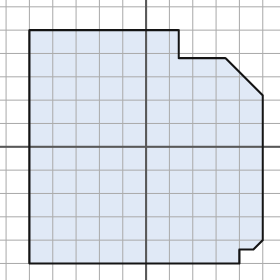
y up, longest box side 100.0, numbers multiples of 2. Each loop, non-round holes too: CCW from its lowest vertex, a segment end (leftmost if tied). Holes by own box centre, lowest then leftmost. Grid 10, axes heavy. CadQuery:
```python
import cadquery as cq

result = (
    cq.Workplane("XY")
    .moveTo(-50.0, -50.0)
    .lineTo(40.0, -50.0)
    .lineTo(40.0, -44.0)
    .lineTo(46.0, -44.0)
    .lineTo(50.0, -40.0)
    .lineTo(50.0, 22.0)
    .lineTo(34.0, 38.0)
    .lineTo(14.0, 38.0)
    .lineTo(14.0, 50.0)
    .lineTo(-50.0, 50.0)
    .close()
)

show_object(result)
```